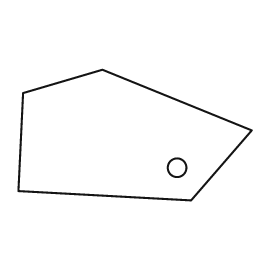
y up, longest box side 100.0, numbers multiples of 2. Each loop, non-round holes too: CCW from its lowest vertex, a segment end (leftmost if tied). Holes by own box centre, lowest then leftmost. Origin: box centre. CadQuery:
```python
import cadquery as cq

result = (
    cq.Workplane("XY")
    .moveTo(24.0, -28.0)
    .lineTo(50.0, 2.0)
    .lineTo(-14.0, 28.0)
    .lineTo(-48.0, 18.0)
    .lineTo(-50.0, -24.0)
    .close()
    .moveTo(18.0, -14.0)
    .circle(4.0)
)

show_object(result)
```